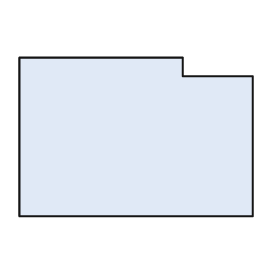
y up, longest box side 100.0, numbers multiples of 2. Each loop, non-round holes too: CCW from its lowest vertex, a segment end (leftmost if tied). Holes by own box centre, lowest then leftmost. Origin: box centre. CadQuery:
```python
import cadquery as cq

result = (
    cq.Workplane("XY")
    .moveTo(-50.0, -34.0)
    .lineTo(50.0, -34.0)
    .lineTo(50.0, 26.0)
    .lineTo(20.0, 26.0)
    .lineTo(20.0, 34.0)
    .lineTo(-50.0, 34.0)
    .close()
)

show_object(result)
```